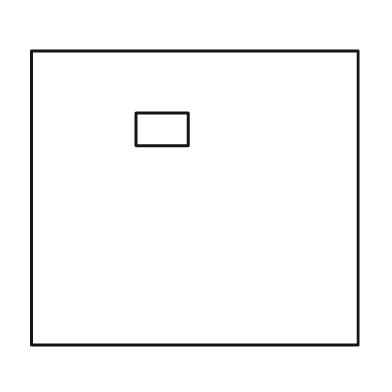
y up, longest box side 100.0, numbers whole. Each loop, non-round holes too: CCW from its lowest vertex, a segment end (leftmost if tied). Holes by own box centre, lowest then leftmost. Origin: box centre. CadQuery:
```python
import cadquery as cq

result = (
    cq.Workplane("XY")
    .moveTo(-50.0, -45.0)
    .lineTo(50.0, -45.0)
    .lineTo(50.0, 45.0)
    .lineTo(-50.0, 45.0)
    .close()
    .moveTo(-18.0, 16.0)
    .lineTo(-2.0, 16.0)
    .lineTo(-2.0, 26.0)
    .lineTo(-18.0, 26.0)
    .close()
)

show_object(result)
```